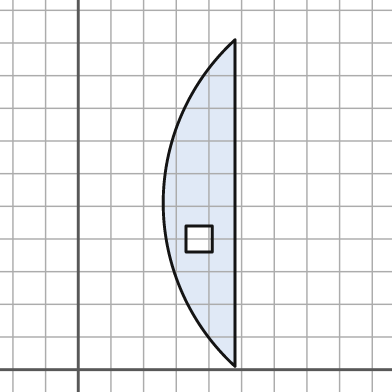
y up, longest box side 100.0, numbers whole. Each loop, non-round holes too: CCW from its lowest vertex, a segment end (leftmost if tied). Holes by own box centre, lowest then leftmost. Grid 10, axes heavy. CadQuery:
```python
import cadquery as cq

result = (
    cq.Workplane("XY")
    .moveTo(48.0, 1.0)
    .lineTo(48.0, 101.0)
    .threePointArc((26.0, 51.0), (48.0, 1.0))
    .close()
    .moveTo(33.0, 36.0)
    .lineTo(41.0, 36.0)
    .lineTo(41.0, 44.0)
    .lineTo(33.0, 44.0)
    .close()
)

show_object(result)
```